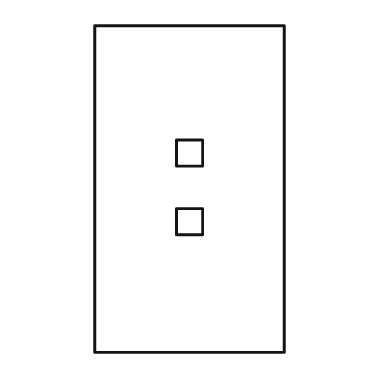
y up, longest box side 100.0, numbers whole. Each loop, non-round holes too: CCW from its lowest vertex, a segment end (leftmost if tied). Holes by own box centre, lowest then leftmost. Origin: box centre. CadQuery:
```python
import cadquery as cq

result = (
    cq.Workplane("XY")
    .moveTo(-29.0, -50.0)
    .lineTo(29.0, -50.0)
    .lineTo(29.0, 50.0)
    .lineTo(-29.0, 50.0)
    .close()
    .moveTo(-4.0, -14.0)
    .lineTo(4.0, -14.0)
    .lineTo(4.0, -6.0)
    .lineTo(-4.0, -6.0)
    .close()
    .moveTo(-4.0, 7.0)
    .lineTo(4.0, 7.0)
    .lineTo(4.0, 15.0)
    .lineTo(-4.0, 15.0)
    .close()
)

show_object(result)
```